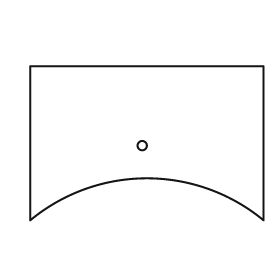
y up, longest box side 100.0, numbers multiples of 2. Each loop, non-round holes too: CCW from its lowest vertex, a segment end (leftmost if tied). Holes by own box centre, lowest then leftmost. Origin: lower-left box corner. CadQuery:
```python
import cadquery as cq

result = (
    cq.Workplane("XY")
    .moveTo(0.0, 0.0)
    .threePointArc((50.0, 18.0), (100.0, 0.0))
    .lineTo(100.0, 66.0)
    .lineTo(0.0, 66.0)
    .close()
    .moveTo(48.0, 32.0)
    .circle(2.0)
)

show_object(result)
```